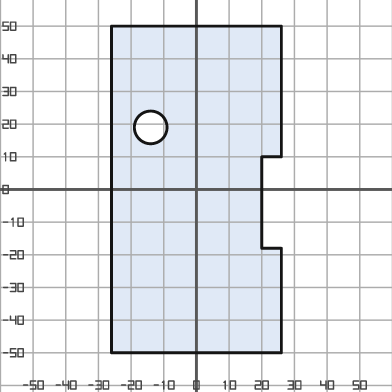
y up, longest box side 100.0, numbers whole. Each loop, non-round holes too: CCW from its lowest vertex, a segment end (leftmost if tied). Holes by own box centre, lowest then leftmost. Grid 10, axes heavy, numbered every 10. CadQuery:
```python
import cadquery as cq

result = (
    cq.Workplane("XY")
    .moveTo(-26.0, -50.0)
    .lineTo(26.0, -50.0)
    .lineTo(26.0, -18.0)
    .lineTo(20.0, -18.0)
    .lineTo(20.0, 10.0)
    .lineTo(26.0, 10.0)
    .lineTo(26.0, 50.0)
    .lineTo(-26.0, 50.0)
    .close()
    .moveTo(-14.0, 19.0)
    .circle(5.0)
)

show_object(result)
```